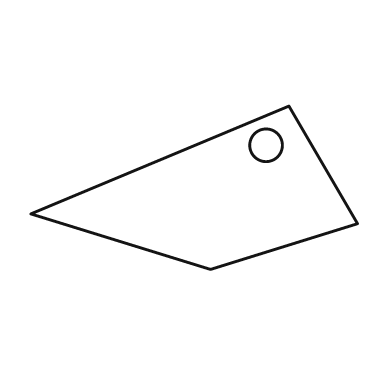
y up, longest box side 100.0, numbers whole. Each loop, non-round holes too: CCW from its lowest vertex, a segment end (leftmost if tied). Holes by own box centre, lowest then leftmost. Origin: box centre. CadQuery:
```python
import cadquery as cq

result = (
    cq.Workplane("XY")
    .moveTo(5.0, -25.0)
    .lineTo(50.0, -11.0)
    .lineTo(29.0, 25.0)
    .lineTo(-50.0, -8.0)
    .close()
    .moveTo(22.0, 13.0)
    .circle(5.0)
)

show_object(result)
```